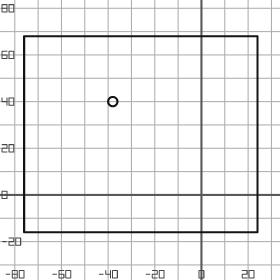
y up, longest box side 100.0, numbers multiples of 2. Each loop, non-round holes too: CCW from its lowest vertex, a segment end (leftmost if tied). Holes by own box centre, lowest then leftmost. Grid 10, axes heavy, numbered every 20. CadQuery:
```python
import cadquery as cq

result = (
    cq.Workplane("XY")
    .moveTo(-76.0, -16.0)
    .lineTo(24.0, -16.0)
    .lineTo(24.0, 68.0)
    .lineTo(-76.0, 68.0)
    .close()
    .moveTo(-38.0, 40.0)
    .circle(2.0)
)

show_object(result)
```